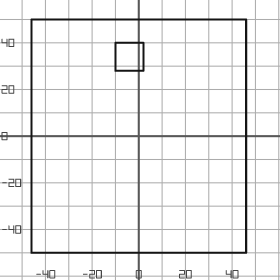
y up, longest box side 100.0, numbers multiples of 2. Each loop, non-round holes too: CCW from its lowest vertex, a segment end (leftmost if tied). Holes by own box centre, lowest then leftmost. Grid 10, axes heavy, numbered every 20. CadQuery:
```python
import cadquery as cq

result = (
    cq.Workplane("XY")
    .moveTo(-46.0, -50.0)
    .lineTo(46.0, -50.0)
    .lineTo(46.0, 50.0)
    .lineTo(-46.0, 50.0)
    .close()
    .moveTo(-10.0, 28.0)
    .lineTo(2.0, 28.0)
    .lineTo(2.0, 40.0)
    .lineTo(-10.0, 40.0)
    .close()
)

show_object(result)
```